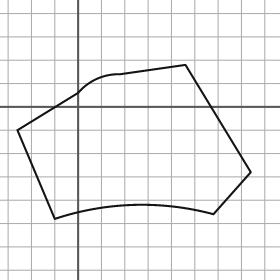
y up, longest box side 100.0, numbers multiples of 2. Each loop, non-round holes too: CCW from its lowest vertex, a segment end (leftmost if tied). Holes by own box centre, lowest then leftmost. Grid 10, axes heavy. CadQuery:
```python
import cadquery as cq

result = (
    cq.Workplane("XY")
    .moveTo(-10.0, -48.0)
    .threePointArc((24.0, -42.0), (58.0, -46.0))
    .lineTo(74.0, -28.0)
    .lineTo(46.0, 18.0)
    .lineTo(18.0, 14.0)
    .threePointArc((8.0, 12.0), (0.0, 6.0))
    .lineTo(-26.0, -10.0)
    .close()
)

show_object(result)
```